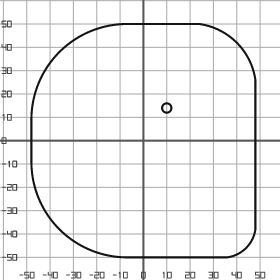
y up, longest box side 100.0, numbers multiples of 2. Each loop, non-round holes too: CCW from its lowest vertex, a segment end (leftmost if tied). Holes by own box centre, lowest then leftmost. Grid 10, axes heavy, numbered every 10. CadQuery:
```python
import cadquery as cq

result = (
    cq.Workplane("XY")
    .moveTo(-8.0, -50.0)
    .lineTo(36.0, -50.0)
    .threePointArc((44.0, -46.0), (48.0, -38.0))
    .lineTo(48.0, 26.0)
    .threePointArc((40.0, 42.0), (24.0, 50.0))
    .lineTo(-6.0, 50.0)
    .threePointArc((-36.0, 38.0), (-48.0, 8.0))
    .lineTo(-48.0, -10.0)
    .threePointArc((-36.0, -38.0), (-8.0, -50.0))
    .close()
    .moveTo(10.0, 14.0)
    .circle(2.0)
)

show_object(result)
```